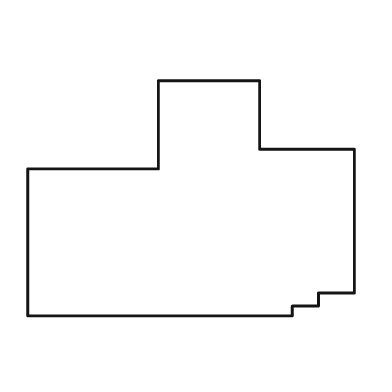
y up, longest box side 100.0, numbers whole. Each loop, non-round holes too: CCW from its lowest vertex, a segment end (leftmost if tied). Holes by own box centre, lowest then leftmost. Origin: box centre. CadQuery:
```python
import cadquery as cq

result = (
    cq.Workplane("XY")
    .moveTo(-50.0, -36.0)
    .lineTo(31.0, -36.0)
    .lineTo(31.0, -33.0)
    .lineTo(39.0, -33.0)
    .lineTo(39.0, -29.0)
    .lineTo(50.0, -29.0)
    .lineTo(50.0, 15.0)
    .lineTo(21.0, 15.0)
    .lineTo(21.0, 36.0)
    .lineTo(-10.0, 36.0)
    .lineTo(-10.0, 9.0)
    .lineTo(-50.0, 9.0)
    .close()
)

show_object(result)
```